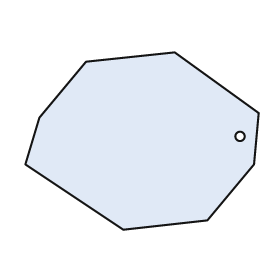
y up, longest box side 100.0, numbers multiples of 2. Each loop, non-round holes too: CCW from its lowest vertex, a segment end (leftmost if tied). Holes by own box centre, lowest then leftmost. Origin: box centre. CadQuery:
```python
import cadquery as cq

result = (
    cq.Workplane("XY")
    .moveTo(-8.0, -38.0)
    .lineTo(28.0, -34.0)
    .lineTo(48.0, -10.0)
    .lineTo(50.0, 12.0)
    .lineTo(14.0, 38.0)
    .lineTo(-24.0, 34.0)
    .lineTo(-44.0, 10.0)
    .lineTo(-50.0, -10.0)
    .close()
    .moveTo(42.0, 2.0)
    .circle(2.0)
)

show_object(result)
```